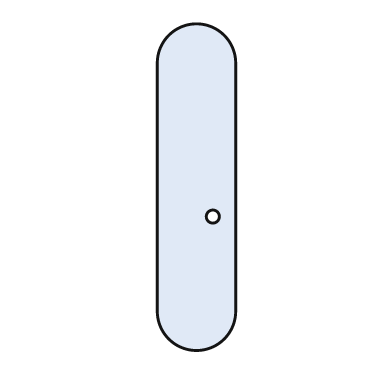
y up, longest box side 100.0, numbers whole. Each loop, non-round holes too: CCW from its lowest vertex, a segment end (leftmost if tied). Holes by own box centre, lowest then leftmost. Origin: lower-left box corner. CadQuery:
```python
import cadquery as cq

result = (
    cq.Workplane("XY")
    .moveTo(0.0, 12.0)
    .threePointArc((12.0, 0.0), (24.0, 12.0))
    .lineTo(24.0, 88.0)
    .threePointArc((12.0, 100.0), (0.0, 88.0))
    .close()
    .moveTo(17.0, 41.0)
    .circle(2.0)
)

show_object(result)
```